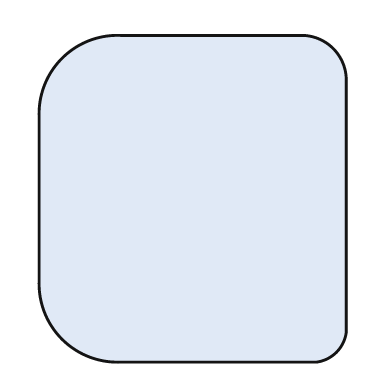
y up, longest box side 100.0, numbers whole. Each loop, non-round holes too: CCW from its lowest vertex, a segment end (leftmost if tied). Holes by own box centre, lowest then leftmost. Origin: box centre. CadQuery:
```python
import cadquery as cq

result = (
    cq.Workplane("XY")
    .moveTo(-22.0, -50.0)
    .lineTo(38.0, -50.0)
    .threePointArc((44.0, -47.0), (47.0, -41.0))
    .lineTo(47.0, 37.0)
    .threePointArc((43.0, 46.0), (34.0, 50.0))
    .lineTo(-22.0, 50.0)
    .threePointArc((-40.0, 43.0), (-47.0, 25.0))
    .lineTo(-47.0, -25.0)
    .threePointArc((-40.0, -43.0), (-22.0, -50.0))
    .close()
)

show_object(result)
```